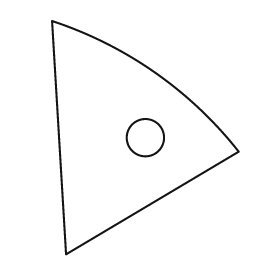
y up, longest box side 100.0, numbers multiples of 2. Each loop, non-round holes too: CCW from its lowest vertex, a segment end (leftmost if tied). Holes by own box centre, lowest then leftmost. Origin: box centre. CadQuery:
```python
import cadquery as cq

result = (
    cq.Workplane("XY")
    .moveTo(-34.0, -50.0)
    .lineTo(40.0, -6.0)
    .threePointArc((4.0, 28.0), (-40.0, 50.0))
    .close()
    .moveTo(0.0, 0.0)
    .circle(8.0)
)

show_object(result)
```